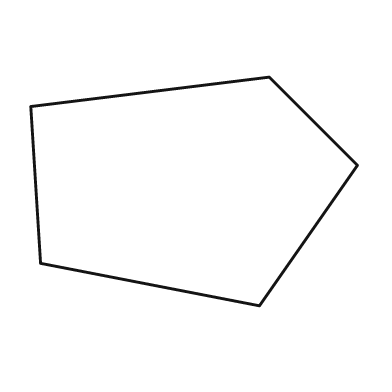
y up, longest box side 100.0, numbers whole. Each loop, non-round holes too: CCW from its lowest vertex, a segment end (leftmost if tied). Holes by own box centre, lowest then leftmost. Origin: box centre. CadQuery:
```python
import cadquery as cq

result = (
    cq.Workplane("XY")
    .moveTo(20.0, -35.0)
    .lineTo(50.0, 8.0)
    .lineTo(23.0, 35.0)
    .lineTo(-50.0, 26.0)
    .lineTo(-47.0, -22.0)
    .close()
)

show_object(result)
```